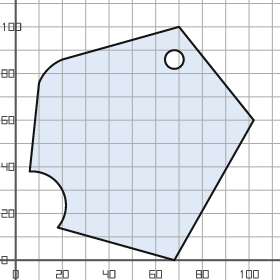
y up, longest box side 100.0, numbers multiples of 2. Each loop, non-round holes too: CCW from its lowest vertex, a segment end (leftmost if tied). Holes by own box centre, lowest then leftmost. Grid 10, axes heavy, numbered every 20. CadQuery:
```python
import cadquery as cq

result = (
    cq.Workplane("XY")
    .moveTo(68.0, 0.0)
    .lineTo(102.0, 60.0)
    .lineTo(70.0, 100.0)
    .lineTo(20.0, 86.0)
    .threePointArc((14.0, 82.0), (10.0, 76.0))
    .lineTo(6.0, 38.0)
    .threePointArc((20.0, 30.0), (18.0, 14.0))
    .close()
    .moveTo(68.0, 86.0)
    .circle(4.0)
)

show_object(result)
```